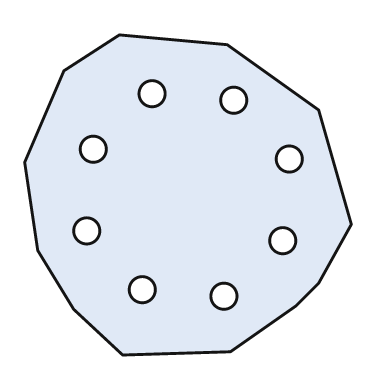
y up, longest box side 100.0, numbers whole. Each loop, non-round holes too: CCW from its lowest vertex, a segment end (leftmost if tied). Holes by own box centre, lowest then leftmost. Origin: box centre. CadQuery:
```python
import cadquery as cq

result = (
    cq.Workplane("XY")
    .moveTo(-20.0, -49.0)
    .lineTo(13.0, -48.0)
    .lineTo(33.0, -34.0)
    .lineTo(40.0, -27.0)
    .lineTo(50.0, -9.0)
    .lineTo(40.0, 26.0)
    .lineTo(12.0, 46.0)
    .lineTo(-21.0, 49.0)
    .lineTo(-38.0, 38.0)
    .lineTo(-50.0, 10.0)
    .lineTo(-46.0, -17.0)
    .lineTo(-35.0, -35.0)
    .close()
    .moveTo(11.0, -31.0)
    .circle(4.0)
    .moveTo(-14.0, -29.0)
    .circle(4.0)
    .moveTo(29.0, -14.0)
    .circle(4.0)
    .moveTo(-31.0, -11.0)
    .circle(4.0)
    .moveTo(31.0, 11.0)
    .circle(4.0)
    .moveTo(-29.0, 14.0)
    .circle(4.0)
    .moveTo(14.0, 29.0)
    .circle(4.0)
    .moveTo(-11.0, 31.0)
    .circle(4.0)
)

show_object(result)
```